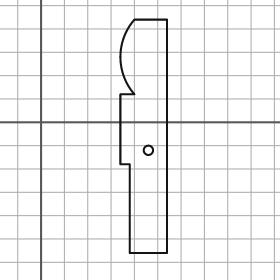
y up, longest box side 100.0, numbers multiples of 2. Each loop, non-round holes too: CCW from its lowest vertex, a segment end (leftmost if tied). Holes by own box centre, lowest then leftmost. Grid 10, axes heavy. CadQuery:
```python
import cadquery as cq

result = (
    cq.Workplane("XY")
    .moveTo(38.0, -56.0)
    .lineTo(54.0, -56.0)
    .lineTo(54.0, 44.0)
    .lineTo(40.0, 44.0)
    .threePointArc((34.0, 28.0), (40.0, 12.0))
    .lineTo(34.0, 12.0)
    .lineTo(34.0, -18.0)
    .lineTo(38.0, -18.0)
    .close()
    .moveTo(46.0, -12.0)
    .circle(2.0)
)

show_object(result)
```